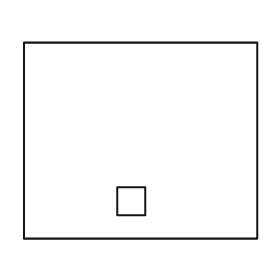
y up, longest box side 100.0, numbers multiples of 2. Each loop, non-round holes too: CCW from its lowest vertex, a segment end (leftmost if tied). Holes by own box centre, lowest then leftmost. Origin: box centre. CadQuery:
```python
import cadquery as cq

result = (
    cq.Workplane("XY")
    .moveTo(-50.0, -42.0)
    .lineTo(50.0, -42.0)
    .lineTo(50.0, 42.0)
    .lineTo(-50.0, 42.0)
    .close()
    .moveTo(-10.0, -32.0)
    .lineTo(2.0, -32.0)
    .lineTo(2.0, -20.0)
    .lineTo(-10.0, -20.0)
    .close()
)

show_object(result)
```